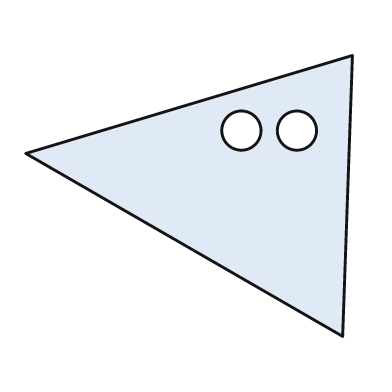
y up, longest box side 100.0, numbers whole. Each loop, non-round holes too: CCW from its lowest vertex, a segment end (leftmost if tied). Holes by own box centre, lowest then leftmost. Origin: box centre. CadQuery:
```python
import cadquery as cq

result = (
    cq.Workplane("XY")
    .moveTo(47.0, -43.0)
    .lineTo(50.0, 43.0)
    .lineTo(-50.0, 13.0)
    .close()
    .moveTo(16.0, 20.0)
    .circle(6.0)
    .moveTo(33.0, 20.0)
    .circle(6.0)
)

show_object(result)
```